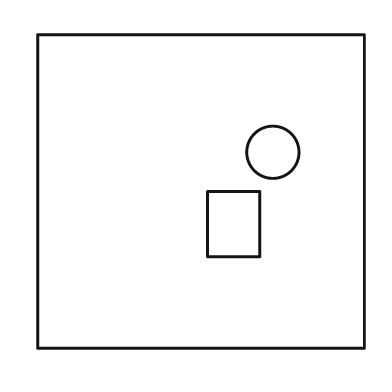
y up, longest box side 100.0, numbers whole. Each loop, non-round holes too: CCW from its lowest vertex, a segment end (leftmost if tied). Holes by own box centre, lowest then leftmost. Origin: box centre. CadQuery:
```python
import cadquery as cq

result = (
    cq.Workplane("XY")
    .moveTo(-50.0, -48.0)
    .lineTo(50.0, -48.0)
    .lineTo(50.0, 48.0)
    .lineTo(-50.0, 48.0)
    .close()
    .moveTo(2.0, -20.0)
    .lineTo(18.0, -20.0)
    .lineTo(18.0, 0.0)
    .lineTo(2.0, 0.0)
    .close()
    .moveTo(22.0, 12.0)
    .circle(8.0)
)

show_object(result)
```